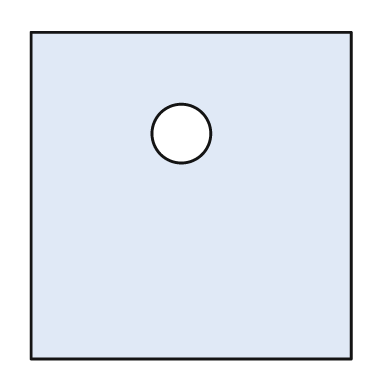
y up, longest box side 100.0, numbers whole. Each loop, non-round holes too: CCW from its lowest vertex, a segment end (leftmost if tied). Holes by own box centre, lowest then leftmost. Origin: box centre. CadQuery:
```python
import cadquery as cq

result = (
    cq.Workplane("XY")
    .moveTo(-49.0, -50.0)
    .lineTo(49.0, -50.0)
    .lineTo(49.0, 50.0)
    .lineTo(-49.0, 50.0)
    .close()
    .moveTo(-3.0, 19.0)
    .circle(9.0)
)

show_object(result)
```